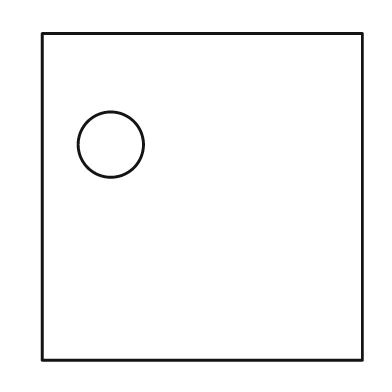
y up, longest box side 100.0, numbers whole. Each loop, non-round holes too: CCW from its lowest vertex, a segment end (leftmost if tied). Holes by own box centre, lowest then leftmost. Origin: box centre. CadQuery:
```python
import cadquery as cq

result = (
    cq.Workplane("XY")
    .moveTo(-49.0, -50.0)
    .lineTo(49.0, -50.0)
    .lineTo(49.0, 50.0)
    .lineTo(-49.0, 50.0)
    .close()
    .moveTo(-28.0, 16.0)
    .circle(10.0)
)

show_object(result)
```